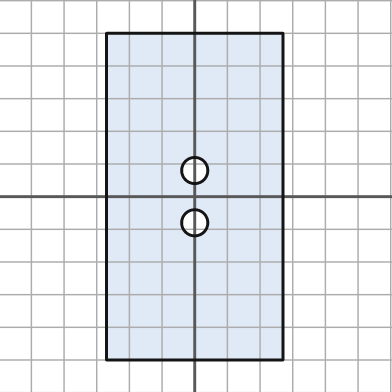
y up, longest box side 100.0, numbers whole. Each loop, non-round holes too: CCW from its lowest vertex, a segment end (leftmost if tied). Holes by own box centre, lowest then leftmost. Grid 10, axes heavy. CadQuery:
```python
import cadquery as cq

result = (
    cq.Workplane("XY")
    .moveTo(-27.0, -50.0)
    .lineTo(27.0, -50.0)
    .lineTo(27.0, 50.0)
    .lineTo(-27.0, 50.0)
    .close()
    .moveTo(0.0, -8.0)
    .circle(4.0)
    .moveTo(0.0, 8.0)
    .circle(4.0)
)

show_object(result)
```